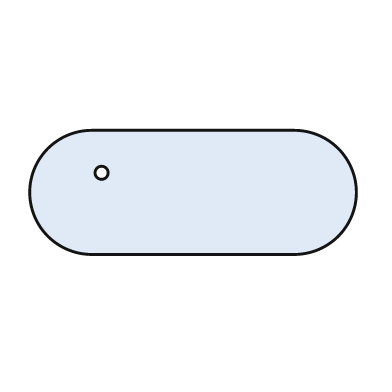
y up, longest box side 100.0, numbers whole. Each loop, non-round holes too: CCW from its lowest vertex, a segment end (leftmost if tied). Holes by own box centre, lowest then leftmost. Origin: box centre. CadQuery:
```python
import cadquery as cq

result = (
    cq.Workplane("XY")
    .moveTo(-31.0, -19.0)
    .lineTo(31.0, -19.0)
    .threePointArc((50.0, 0.0), (31.0, 19.0))
    .lineTo(-31.0, 19.0)
    .threePointArc((-50.0, 0.0), (-31.0, -19.0))
    .close()
    .moveTo(-28.0, 6.0)
    .circle(2.0)
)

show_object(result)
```